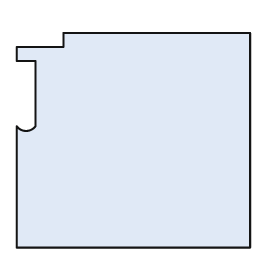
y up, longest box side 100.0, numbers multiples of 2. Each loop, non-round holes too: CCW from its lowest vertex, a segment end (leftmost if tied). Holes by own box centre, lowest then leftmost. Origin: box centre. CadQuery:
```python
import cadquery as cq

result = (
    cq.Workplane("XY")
    .moveTo(-50.0, -46.0)
    .lineTo(50.0, -46.0)
    .lineTo(50.0, 46.0)
    .lineTo(-30.0, 46.0)
    .lineTo(-30.0, 40.0)
    .lineTo(-50.0, 40.0)
    .lineTo(-50.0, 34.0)
    .lineTo(-42.0, 34.0)
    .lineTo(-42.0, 6.0)
    .threePointArc((-46.0, 4.0), (-50.0, 6.0))
    .close()
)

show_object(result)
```